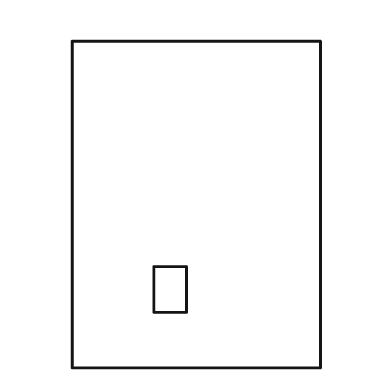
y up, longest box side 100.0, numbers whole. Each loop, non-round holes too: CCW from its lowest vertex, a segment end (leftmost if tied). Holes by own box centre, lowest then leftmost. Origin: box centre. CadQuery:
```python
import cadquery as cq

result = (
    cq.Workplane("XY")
    .moveTo(-38.0, -50.0)
    .lineTo(38.0, -50.0)
    .lineTo(38.0, 50.0)
    .lineTo(-38.0, 50.0)
    .close()
    .moveTo(-13.0, -33.0)
    .lineTo(-3.0, -33.0)
    .lineTo(-3.0, -19.0)
    .lineTo(-13.0, -19.0)
    .close()
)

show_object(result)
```